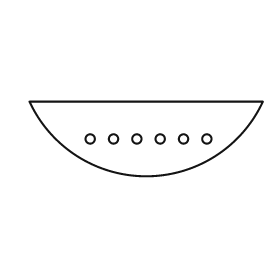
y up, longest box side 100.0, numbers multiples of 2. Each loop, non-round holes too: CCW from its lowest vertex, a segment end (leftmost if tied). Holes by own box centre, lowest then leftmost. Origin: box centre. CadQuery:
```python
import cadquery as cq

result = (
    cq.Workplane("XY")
    .moveTo(-50.0, 16.0)
    .threePointArc((0.0, -16.0), (50.0, 16.0))
    .close()
    .moveTo(-24.0, 0.0)
    .circle(2.0)
    .moveTo(-14.0, 0.0)
    .circle(2.0)
    .moveTo(-4.0, 0.0)
    .circle(2.0)
    .moveTo(6.0, 0.0)
    .circle(2.0)
    .moveTo(16.0, 0.0)
    .circle(2.0)
    .moveTo(26.0, 0.0)
    .circle(2.0)
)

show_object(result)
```